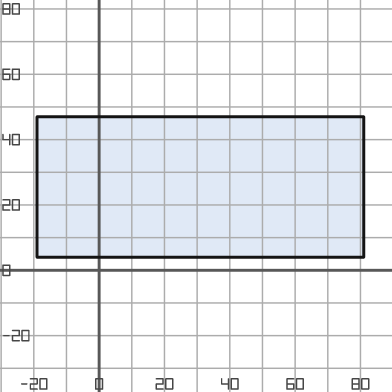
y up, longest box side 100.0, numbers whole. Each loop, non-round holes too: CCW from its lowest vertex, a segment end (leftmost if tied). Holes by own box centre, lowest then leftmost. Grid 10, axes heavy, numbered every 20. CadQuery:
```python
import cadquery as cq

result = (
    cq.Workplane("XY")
    .moveTo(-19.0, 4.0)
    .lineTo(81.0, 4.0)
    .lineTo(81.0, 47.0)
    .lineTo(-19.0, 47.0)
    .close()
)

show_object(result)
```